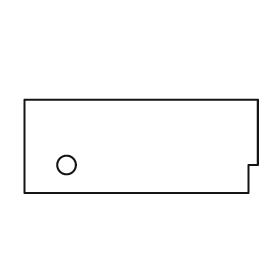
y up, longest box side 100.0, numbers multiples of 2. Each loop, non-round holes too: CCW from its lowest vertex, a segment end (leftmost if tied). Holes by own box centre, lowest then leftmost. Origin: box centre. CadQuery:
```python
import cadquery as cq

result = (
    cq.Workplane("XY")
    .moveTo(-50.0, -20.0)
    .lineTo(46.0, -20.0)
    .lineTo(46.0, -8.0)
    .lineTo(50.0, -8.0)
    .lineTo(50.0, 20.0)
    .lineTo(-50.0, 20.0)
    .close()
    .moveTo(-32.0, -8.0)
    .circle(4.0)
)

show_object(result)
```